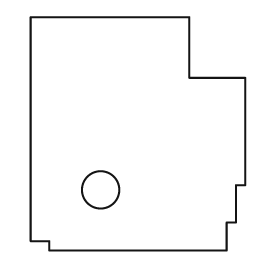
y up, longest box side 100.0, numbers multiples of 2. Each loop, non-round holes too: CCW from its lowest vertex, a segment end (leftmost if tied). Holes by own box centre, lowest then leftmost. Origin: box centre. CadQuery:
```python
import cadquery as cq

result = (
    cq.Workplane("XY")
    .moveTo(-38.0, -50.0)
    .lineTo(38.0, -50.0)
    .lineTo(38.0, -38.0)
    .lineTo(42.0, -38.0)
    .lineTo(42.0, -22.0)
    .lineTo(46.0, -22.0)
    .lineTo(46.0, 24.0)
    .lineTo(22.0, 24.0)
    .lineTo(22.0, 50.0)
    .lineTo(-46.0, 50.0)
    .lineTo(-46.0, -46.0)
    .lineTo(-38.0, -46.0)
    .close()
    .moveTo(-16.0, -24.0)
    .circle(8.0)
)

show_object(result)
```